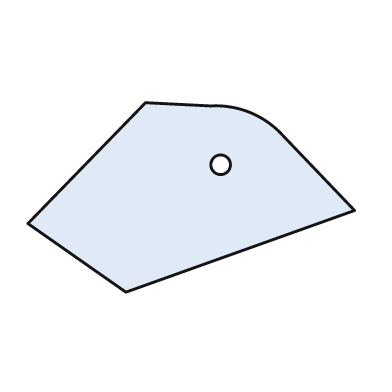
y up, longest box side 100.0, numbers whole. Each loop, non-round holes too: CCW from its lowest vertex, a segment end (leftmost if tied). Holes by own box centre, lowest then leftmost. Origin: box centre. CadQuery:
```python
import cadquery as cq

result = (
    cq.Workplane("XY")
    .moveTo(-20.0, -29.0)
    .lineTo(50.0, -4.0)
    .lineTo(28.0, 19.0)
    .threePointArc((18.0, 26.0), (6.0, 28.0))
    .lineTo(-14.0, 29.0)
    .lineTo(-50.0, -8.0)
    .close()
    .moveTo(9.0, 10.0)
    .circle(3.0)
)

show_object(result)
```